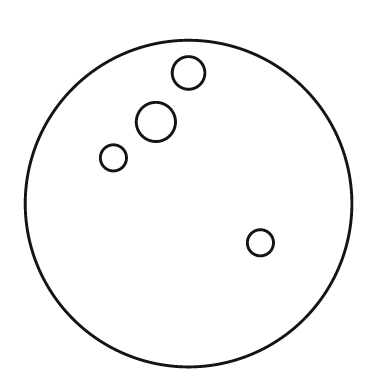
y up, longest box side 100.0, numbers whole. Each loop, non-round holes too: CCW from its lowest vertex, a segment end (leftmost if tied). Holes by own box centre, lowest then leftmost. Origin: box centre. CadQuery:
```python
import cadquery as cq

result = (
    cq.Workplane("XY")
    .moveTo(0.0, 0.0)
    .circle(50.0)
    .moveTo(22.0, -12.0)
    .circle(4.0)
    .moveTo(-23.0, 14.0)
    .circle(4.0)
    .moveTo(-10.0, 25.0)
    .circle(6.0)
    .moveTo(0.0, 40.0)
    .circle(5.0)
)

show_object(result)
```